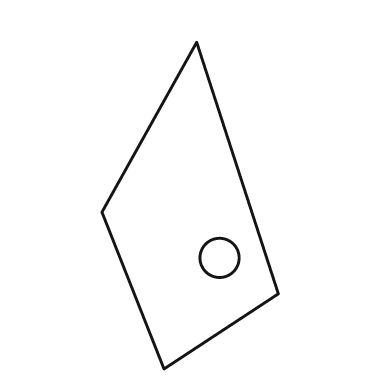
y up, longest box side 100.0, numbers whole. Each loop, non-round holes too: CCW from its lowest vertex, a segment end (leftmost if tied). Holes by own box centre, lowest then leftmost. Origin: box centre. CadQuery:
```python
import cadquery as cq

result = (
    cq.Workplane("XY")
    .moveTo(-8.0, -50.0)
    .lineTo(27.0, -27.0)
    .lineTo(2.0, 50.0)
    .lineTo(-27.0, -2.0)
    .close()
    .moveTo(9.0, -16.0)
    .circle(6.0)
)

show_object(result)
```